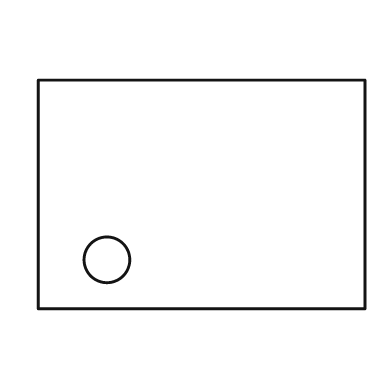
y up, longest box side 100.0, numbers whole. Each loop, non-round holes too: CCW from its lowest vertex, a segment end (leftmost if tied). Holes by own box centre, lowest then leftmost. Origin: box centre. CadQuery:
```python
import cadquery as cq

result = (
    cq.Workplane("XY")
    .moveTo(-50.0, -35.0)
    .lineTo(50.0, -35.0)
    .lineTo(50.0, 35.0)
    .lineTo(-50.0, 35.0)
    .close()
    .moveTo(-29.0, -20.0)
    .circle(7.0)
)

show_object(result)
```